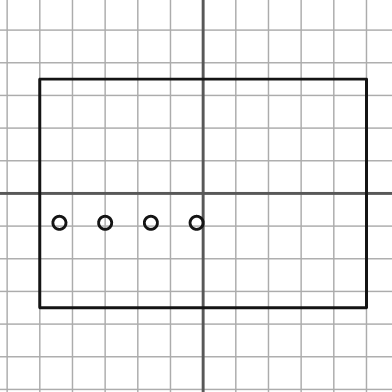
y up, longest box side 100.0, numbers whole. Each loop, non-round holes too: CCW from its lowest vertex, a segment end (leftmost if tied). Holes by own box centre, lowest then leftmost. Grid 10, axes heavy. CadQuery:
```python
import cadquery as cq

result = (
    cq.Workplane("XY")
    .moveTo(-50.0, -35.0)
    .lineTo(50.0, -35.0)
    .lineTo(50.0, 35.0)
    .lineTo(-50.0, 35.0)
    .close()
    .moveTo(-44.0, -9.0)
    .circle(2.0)
    .moveTo(-30.0, -9.0)
    .circle(2.0)
    .moveTo(-16.0, -9.0)
    .circle(2.0)
    .moveTo(-2.0, -9.0)
    .circle(2.0)
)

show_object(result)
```